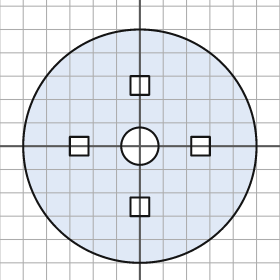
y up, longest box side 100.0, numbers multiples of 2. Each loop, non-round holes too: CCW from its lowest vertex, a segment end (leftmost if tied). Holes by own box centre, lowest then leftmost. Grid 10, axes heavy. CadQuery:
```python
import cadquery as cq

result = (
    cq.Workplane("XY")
    .moveTo(0.0, 0.0)
    .circle(50.0)
    .moveTo(-4.0, -30.0)
    .lineTo(4.0, -30.0)
    .lineTo(4.0, -22.0)
    .lineTo(-4.0, -22.0)
    .close()
    .moveTo(-30.0, -4.0)
    .lineTo(-22.0, -4.0)
    .lineTo(-22.0, 4.0)
    .lineTo(-30.0, 4.0)
    .close()
    .moveTo(0.0, 0.0)
    .circle(8.0)
    .moveTo(22.0, -4.0)
    .lineTo(30.0, -4.0)
    .lineTo(30.0, 4.0)
    .lineTo(22.0, 4.0)
    .close()
    .moveTo(-4.0, 22.0)
    .lineTo(4.0, 22.0)
    .lineTo(4.0, 30.0)
    .lineTo(-4.0, 30.0)
    .close()
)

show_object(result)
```